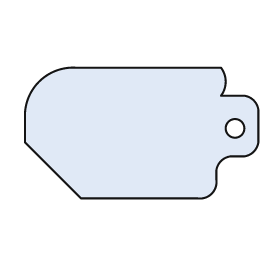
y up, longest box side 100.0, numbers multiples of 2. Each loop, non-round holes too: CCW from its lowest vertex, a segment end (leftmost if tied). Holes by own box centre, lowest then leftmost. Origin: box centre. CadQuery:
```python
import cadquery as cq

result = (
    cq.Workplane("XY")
    .moveTo(-26.0, -28.0)
    .lineTo(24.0, -28.0)
    .threePointArc((30.0, -26.0), (32.0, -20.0))
    .lineTo(32.0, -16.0)
    .threePointArc((34.0, -12.0), (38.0, -10.0))
    .lineTo(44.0, -10.0)
    .threePointArc((48.0, -8.0), (50.0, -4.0))
    .lineTo(50.0, 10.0)
    .threePointArc((48.0, 14.0), (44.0, 16.0))
    .lineTo(34.0, 16.0)
    .threePointArc((36.0, 22.0), (34.0, 28.0))
    .lineTo(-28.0, 28.0)
    .threePointArc((-44.0, 22.0), (-50.0, 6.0))
    .lineTo(-50.0, -4.0)
    .close()
    .moveTo(40.0, 2.0)
    .circle(4.0)
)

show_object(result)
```